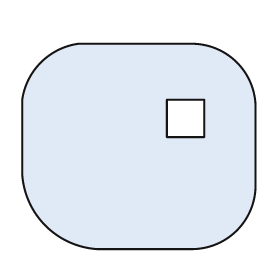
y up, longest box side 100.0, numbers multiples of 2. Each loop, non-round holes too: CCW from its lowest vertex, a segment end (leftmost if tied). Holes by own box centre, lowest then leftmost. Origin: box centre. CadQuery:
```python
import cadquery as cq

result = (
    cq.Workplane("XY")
    .moveTo(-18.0, -44.0)
    .lineTo(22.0, -44.0)
    .threePointArc((42.0, -36.0), (50.0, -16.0))
    .lineTo(50.0, 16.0)
    .threePointArc((42.0, 36.0), (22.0, 44.0))
    .lineTo(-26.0, 44.0)
    .threePointArc((-42.0, 36.0), (-50.0, 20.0))
    .lineTo(-50.0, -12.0)
    .threePointArc((-40.0, -34.0), (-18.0, -44.0))
    .close()
    .moveTo(12.0, 4.0)
    .lineTo(28.0, 4.0)
    .lineTo(28.0, 20.0)
    .lineTo(12.0, 20.0)
    .close()
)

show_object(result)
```